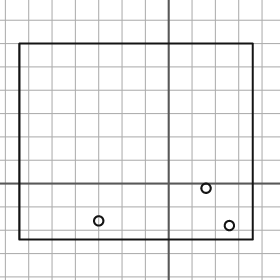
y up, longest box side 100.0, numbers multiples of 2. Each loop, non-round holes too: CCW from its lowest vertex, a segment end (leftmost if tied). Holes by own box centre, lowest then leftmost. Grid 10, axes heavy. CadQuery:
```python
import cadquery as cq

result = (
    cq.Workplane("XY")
    .moveTo(-64.0, -24.0)
    .lineTo(36.0, -24.0)
    .lineTo(36.0, 60.0)
    .lineTo(-64.0, 60.0)
    .close()
    .moveTo(26.0, -18.0)
    .circle(2.0)
    .moveTo(-30.0, -16.0)
    .circle(2.0)
    .moveTo(16.0, -2.0)
    .circle(2.0)
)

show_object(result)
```